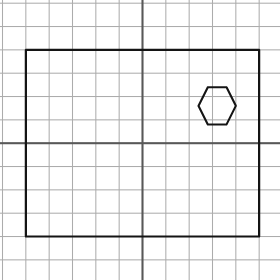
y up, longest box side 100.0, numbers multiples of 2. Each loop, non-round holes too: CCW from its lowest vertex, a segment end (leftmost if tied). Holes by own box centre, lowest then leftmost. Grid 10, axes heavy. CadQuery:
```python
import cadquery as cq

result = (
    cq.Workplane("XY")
    .moveTo(-50.0, -40.0)
    .lineTo(50.0, -40.0)
    .lineTo(50.0, 40.0)
    .lineTo(-50.0, 40.0)
    .close()
    .moveTo(28.0, 8.0)
    .lineTo(36.0, 8.0)
    .lineTo(40.0, 16.0)
    .lineTo(36.0, 24.0)
    .lineTo(28.0, 24.0)
    .lineTo(24.0, 16.0)
    .close()
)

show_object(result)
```